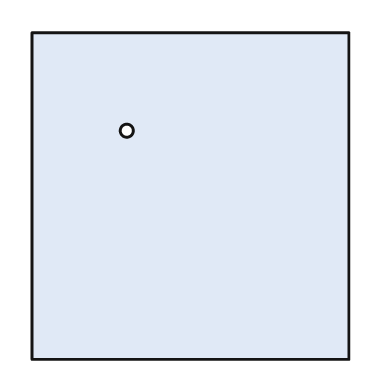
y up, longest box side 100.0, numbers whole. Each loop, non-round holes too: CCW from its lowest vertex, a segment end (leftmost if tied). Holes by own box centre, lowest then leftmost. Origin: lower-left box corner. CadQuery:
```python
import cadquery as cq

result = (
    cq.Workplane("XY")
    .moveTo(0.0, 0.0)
    .lineTo(97.0, 0.0)
    .lineTo(97.0, 100.0)
    .lineTo(0.0, 100.0)
    .close()
    .moveTo(29.0, 70.0)
    .circle(2.0)
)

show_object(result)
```